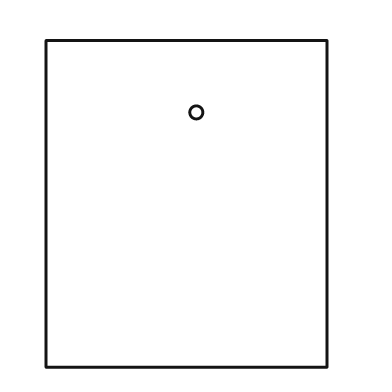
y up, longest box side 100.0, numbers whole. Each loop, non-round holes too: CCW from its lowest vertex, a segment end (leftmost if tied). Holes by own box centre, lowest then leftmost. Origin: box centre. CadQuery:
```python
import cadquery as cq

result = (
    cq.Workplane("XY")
    .moveTo(-43.0, -50.0)
    .lineTo(43.0, -50.0)
    .lineTo(43.0, 50.0)
    .lineTo(-43.0, 50.0)
    .close()
    .moveTo(3.0, 28.0)
    .circle(2.0)
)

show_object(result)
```